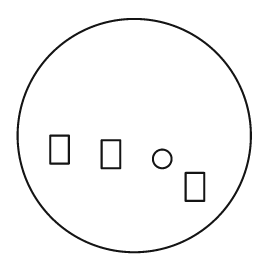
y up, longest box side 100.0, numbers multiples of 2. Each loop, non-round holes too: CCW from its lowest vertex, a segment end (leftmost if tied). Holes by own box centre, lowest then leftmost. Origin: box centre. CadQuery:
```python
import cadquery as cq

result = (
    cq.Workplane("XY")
    .moveTo(0.0, 0.0)
    .circle(50.0)
    .moveTo(22.0, -28.0)
    .lineTo(30.0, -28.0)
    .lineTo(30.0, -16.0)
    .lineTo(22.0, -16.0)
    .close()
    .moveTo(12.0, -10.0)
    .circle(4.0)
    .moveTo(-14.0, -14.0)
    .lineTo(-6.0, -14.0)
    .lineTo(-6.0, -2.0)
    .lineTo(-14.0, -2.0)
    .close()
    .moveTo(-36.0, -12.0)
    .lineTo(-28.0, -12.0)
    .lineTo(-28.0, 0.0)
    .lineTo(-36.0, 0.0)
    .close()
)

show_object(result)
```